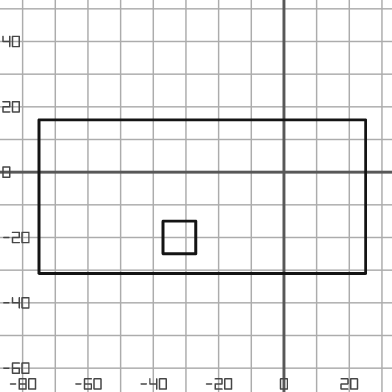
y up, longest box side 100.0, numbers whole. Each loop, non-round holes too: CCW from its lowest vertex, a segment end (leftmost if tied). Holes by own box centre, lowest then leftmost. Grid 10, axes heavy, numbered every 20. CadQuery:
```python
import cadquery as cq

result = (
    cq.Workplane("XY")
    .moveTo(-75.0, -31.0)
    .lineTo(25.0, -31.0)
    .lineTo(25.0, 16.0)
    .lineTo(-75.0, 16.0)
    .close()
    .moveTo(-37.0, -25.0)
    .lineTo(-27.0, -25.0)
    .lineTo(-27.0, -15.0)
    .lineTo(-37.0, -15.0)
    .close()
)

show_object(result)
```